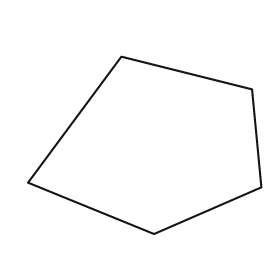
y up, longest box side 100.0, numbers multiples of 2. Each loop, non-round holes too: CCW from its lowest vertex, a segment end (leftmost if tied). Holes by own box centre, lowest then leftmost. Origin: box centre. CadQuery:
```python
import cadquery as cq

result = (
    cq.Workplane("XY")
    .moveTo(4.0, -38.0)
    .lineTo(50.0, -18.0)
    .lineTo(46.0, 24.0)
    .lineTo(-10.0, 38.0)
    .lineTo(-50.0, -16.0)
    .close()
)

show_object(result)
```